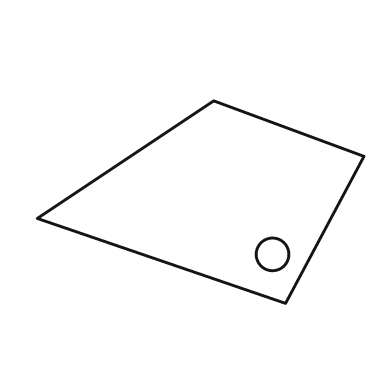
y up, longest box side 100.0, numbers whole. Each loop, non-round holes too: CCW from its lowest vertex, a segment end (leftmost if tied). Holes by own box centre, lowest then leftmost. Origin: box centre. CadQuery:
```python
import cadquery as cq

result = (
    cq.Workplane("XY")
    .moveTo(26.0, -31.0)
    .lineTo(50.0, 14.0)
    .lineTo(4.0, 31.0)
    .lineTo(-50.0, -5.0)
    .close()
    .moveTo(22.0, -16.0)
    .circle(5.0)
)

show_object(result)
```